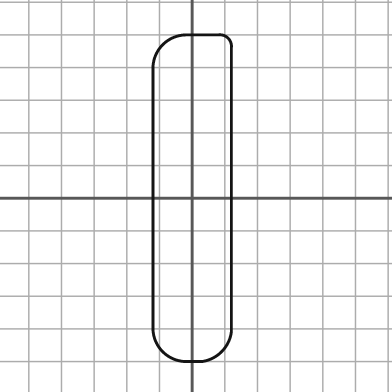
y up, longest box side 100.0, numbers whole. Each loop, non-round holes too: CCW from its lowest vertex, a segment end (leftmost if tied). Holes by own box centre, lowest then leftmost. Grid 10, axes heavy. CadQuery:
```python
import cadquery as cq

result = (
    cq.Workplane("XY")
    .moveTo(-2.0, -50.0)
    .lineTo(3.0, -50.0)
    .threePointArc((9.0, -47.0), (12.0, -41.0))
    .lineTo(12.0, 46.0)
    .threePointArc((11.0, 49.0), (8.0, 50.0))
    .lineTo(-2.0, 50.0)
    .threePointArc((-9.0, 47.0), (-12.0, 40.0))
    .lineTo(-12.0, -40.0)
    .threePointArc((-9.0, -47.0), (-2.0, -50.0))
    .close()
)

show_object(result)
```